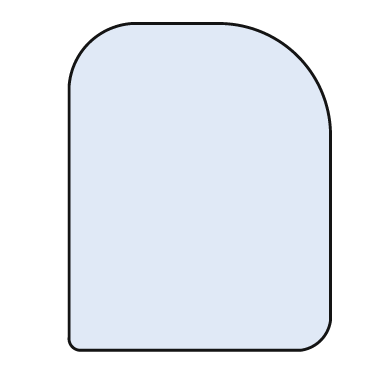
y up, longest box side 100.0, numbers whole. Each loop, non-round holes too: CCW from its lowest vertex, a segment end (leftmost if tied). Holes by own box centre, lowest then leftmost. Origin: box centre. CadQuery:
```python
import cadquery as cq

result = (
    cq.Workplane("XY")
    .moveTo(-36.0, -50.0)
    .lineTo(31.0, -50.0)
    .threePointArc((37.0, -47.0), (40.0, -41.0))
    .lineTo(40.0, 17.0)
    .threePointArc((30.0, 40.0), (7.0, 50.0))
    .lineTo(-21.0, 50.0)
    .threePointArc((-34.0, 44.0), (-40.0, 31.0))
    .lineTo(-40.0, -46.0)
    .threePointArc((-39.0, -49.0), (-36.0, -50.0))
    .close()
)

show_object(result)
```